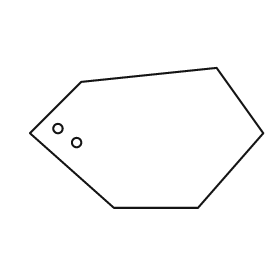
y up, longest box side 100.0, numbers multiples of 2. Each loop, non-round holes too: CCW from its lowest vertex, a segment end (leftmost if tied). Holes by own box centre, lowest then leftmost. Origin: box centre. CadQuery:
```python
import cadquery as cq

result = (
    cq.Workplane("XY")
    .moveTo(-14.0, -30.0)
    .lineTo(22.0, -30.0)
    .lineTo(50.0, 2.0)
    .lineTo(30.0, 30.0)
    .lineTo(-28.0, 24.0)
    .lineTo(-50.0, 2.0)
    .close()
    .moveTo(-30.0, -2.0)
    .circle(2.0)
    .moveTo(-38.0, 4.0)
    .circle(2.0)
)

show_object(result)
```